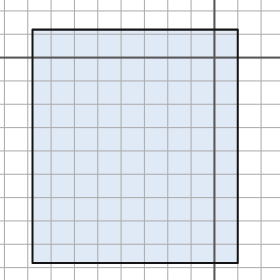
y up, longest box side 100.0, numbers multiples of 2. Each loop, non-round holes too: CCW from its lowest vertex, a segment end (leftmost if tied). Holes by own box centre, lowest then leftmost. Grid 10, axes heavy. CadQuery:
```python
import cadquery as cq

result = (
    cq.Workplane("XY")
    .moveTo(-78.0, -88.0)
    .lineTo(10.0, -88.0)
    .lineTo(10.0, 12.0)
    .lineTo(-78.0, 12.0)
    .close()
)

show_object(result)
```